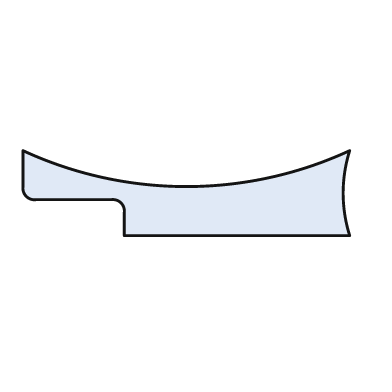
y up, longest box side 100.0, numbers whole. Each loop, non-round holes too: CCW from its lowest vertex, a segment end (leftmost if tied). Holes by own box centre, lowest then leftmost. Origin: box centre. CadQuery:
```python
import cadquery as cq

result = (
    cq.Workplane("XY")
    .moveTo(-19.0, -13.0)
    .lineTo(50.0, -13.0)
    .threePointArc((48.0, 0.0), (50.0, 13.0))
    .threePointArc((0.0, 2.0), (-50.0, 13.0))
    .lineTo(-50.0, 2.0)
    .threePointArc((-49.0, -1.0), (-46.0, -2.0))
    .lineTo(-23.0, -2.0)
    .threePointArc((-20.0, -3.0), (-19.0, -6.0))
    .close()
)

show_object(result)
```